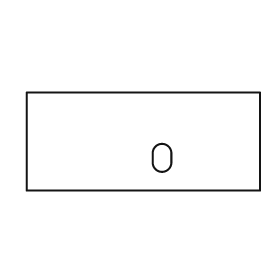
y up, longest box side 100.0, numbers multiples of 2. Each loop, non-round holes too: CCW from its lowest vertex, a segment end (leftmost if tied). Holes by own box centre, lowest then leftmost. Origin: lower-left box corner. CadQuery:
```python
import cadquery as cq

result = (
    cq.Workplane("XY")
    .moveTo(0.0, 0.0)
    .lineTo(100.0, 0.0)
    .lineTo(100.0, 42.0)
    .lineTo(0.0, 42.0)
    .close()
    .moveTo(54.0, 12.0)
    .threePointArc((58.0, 8.0), (62.0, 12.0))
    .lineTo(62.0, 16.0)
    .threePointArc((58.0, 20.0), (54.0, 16.0))
    .close()
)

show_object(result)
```